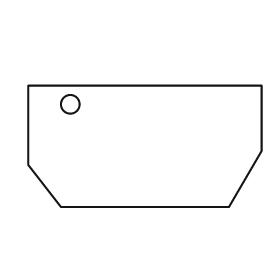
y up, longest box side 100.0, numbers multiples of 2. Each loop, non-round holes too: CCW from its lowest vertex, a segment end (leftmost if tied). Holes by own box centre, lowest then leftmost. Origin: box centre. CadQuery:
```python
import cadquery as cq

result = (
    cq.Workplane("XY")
    .moveTo(-36.0, -26.0)
    .lineTo(36.0, -26.0)
    .lineTo(50.0, -2.0)
    .lineTo(50.0, 26.0)
    .lineTo(-50.0, 26.0)
    .lineTo(-50.0, -8.0)
    .close()
    .moveTo(-32.0, 18.0)
    .circle(4.0)
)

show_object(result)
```